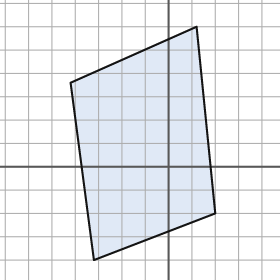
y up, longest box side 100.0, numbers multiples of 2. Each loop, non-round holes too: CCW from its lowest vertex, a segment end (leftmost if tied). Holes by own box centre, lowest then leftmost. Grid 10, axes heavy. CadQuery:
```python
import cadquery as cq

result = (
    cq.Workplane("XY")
    .moveTo(-32.0, -40.0)
    .lineTo(20.0, -20.0)
    .lineTo(12.0, 60.0)
    .lineTo(-42.0, 36.0)
    .close()
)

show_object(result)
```